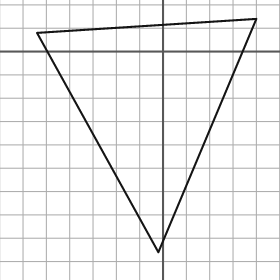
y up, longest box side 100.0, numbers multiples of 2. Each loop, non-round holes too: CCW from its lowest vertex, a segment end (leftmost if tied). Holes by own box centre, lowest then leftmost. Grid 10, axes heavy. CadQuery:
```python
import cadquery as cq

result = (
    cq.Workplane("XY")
    .moveTo(-2.0, -86.0)
    .lineTo(40.0, 14.0)
    .lineTo(-54.0, 8.0)
    .close()
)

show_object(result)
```